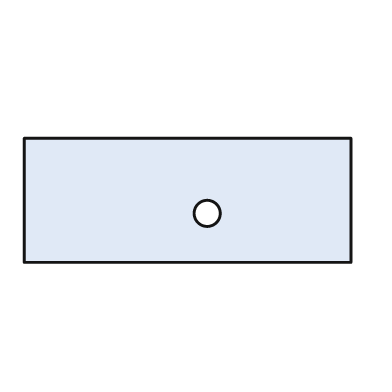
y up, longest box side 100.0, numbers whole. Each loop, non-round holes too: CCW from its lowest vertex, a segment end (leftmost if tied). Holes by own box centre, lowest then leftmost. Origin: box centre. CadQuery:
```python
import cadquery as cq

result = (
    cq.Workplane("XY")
    .moveTo(-50.0, -19.0)
    .lineTo(50.0, -19.0)
    .lineTo(50.0, 19.0)
    .lineTo(-50.0, 19.0)
    .close()
    .moveTo(6.0, -4.0)
    .circle(4.0)
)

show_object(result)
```